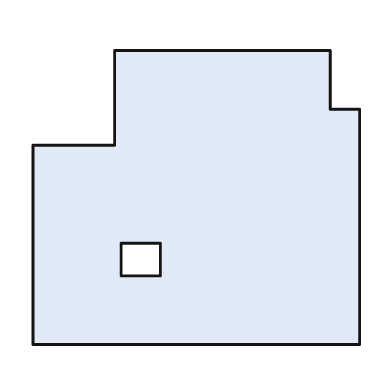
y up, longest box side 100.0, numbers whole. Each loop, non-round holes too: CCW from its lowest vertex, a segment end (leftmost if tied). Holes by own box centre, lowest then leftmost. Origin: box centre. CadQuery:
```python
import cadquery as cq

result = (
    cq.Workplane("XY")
    .moveTo(-50.0, -45.0)
    .lineTo(50.0, -45.0)
    .lineTo(50.0, 27.0)
    .lineTo(41.0, 27.0)
    .lineTo(41.0, 45.0)
    .lineTo(-25.0, 45.0)
    .lineTo(-25.0, 16.0)
    .lineTo(-50.0, 16.0)
    .close()
    .moveTo(-23.0, -24.0)
    .lineTo(-11.0, -24.0)
    .lineTo(-11.0, -14.0)
    .lineTo(-23.0, -14.0)
    .close()
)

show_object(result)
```